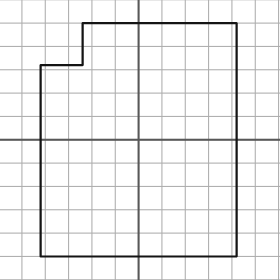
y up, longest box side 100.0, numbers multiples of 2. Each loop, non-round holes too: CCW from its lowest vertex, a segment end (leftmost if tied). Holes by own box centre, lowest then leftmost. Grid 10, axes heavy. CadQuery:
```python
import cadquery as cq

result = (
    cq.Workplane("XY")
    .moveTo(-42.0, -50.0)
    .lineTo(42.0, -50.0)
    .lineTo(42.0, 50.0)
    .lineTo(-24.0, 50.0)
    .lineTo(-24.0, 32.0)
    .lineTo(-42.0, 32.0)
    .close()
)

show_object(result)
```